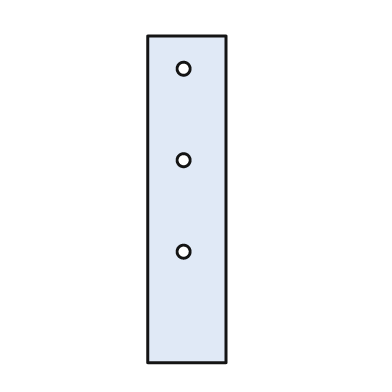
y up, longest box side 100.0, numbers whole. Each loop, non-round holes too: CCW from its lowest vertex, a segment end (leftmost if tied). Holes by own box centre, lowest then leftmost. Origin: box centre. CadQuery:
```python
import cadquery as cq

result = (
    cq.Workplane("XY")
    .moveTo(-12.0, -50.0)
    .lineTo(12.0, -50.0)
    .lineTo(12.0, 50.0)
    .lineTo(-12.0, 50.0)
    .close()
    .moveTo(-1.0, -16.0)
    .circle(2.0)
    .moveTo(-1.0, 12.0)
    .circle(2.0)
    .moveTo(-1.0, 40.0)
    .circle(2.0)
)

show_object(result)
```